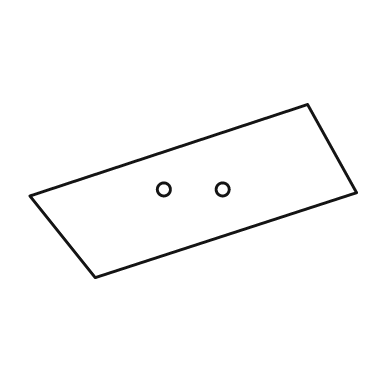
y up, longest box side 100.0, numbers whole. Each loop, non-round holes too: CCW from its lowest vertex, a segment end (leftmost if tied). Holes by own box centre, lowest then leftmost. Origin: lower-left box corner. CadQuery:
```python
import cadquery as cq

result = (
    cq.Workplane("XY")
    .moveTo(20.0, 0.0)
    .lineTo(100.0, 26.0)
    .lineTo(85.0, 53.0)
    .lineTo(0.0, 25.0)
    .close()
    .moveTo(41.0, 27.0)
    .circle(2.0)
    .moveTo(59.0, 27.0)
    .circle(2.0)
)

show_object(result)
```